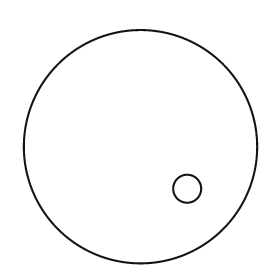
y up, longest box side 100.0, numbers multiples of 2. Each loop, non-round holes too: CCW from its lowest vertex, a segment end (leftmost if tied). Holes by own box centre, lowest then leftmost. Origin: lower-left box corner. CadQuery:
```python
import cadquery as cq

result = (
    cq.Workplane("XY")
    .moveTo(50.0, 50.0)
    .circle(50.0)
    .moveTo(70.0, 32.0)
    .circle(6.0)
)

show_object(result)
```